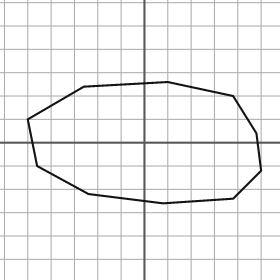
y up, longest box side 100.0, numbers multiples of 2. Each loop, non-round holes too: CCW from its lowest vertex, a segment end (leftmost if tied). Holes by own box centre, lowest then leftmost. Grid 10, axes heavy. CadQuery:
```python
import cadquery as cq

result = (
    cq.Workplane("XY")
    .moveTo(8.0, -26.0)
    .lineTo(38.0, -24.0)
    .lineTo(50.0, -12.0)
    .lineTo(48.0, 4.0)
    .lineTo(38.0, 20.0)
    .lineTo(10.0, 26.0)
    .lineTo(-26.0, 24.0)
    .lineTo(-50.0, 10.0)
    .lineTo(-46.0, -10.0)
    .lineTo(-24.0, -22.0)
    .close()
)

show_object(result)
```